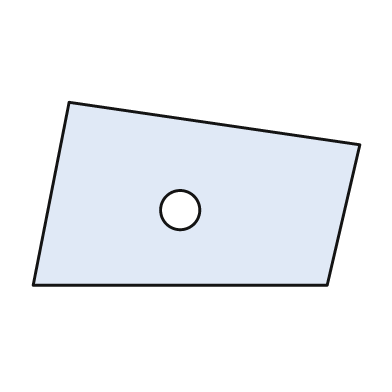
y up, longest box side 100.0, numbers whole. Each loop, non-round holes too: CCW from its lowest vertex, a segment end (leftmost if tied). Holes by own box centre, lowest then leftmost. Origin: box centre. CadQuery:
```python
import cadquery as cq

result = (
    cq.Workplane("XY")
    .moveTo(-50.0, -28.0)
    .lineTo(40.0, -28.0)
    .lineTo(50.0, 15.0)
    .lineTo(-39.0, 28.0)
    .close()
    .moveTo(-5.0, -5.0)
    .circle(6.0)
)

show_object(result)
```